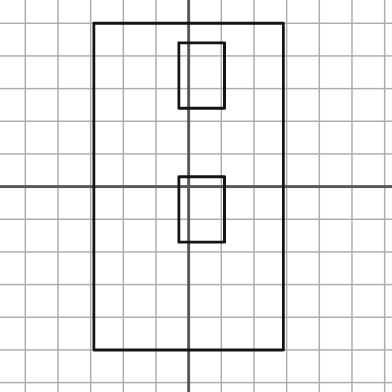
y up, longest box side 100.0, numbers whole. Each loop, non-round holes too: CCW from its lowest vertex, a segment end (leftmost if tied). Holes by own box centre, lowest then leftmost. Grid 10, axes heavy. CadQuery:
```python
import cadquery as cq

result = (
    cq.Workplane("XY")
    .moveTo(-29.0, -50.0)
    .lineTo(29.0, -50.0)
    .lineTo(29.0, 50.0)
    .lineTo(-29.0, 50.0)
    .close()
    .moveTo(-3.0, -17.0)
    .lineTo(11.0, -17.0)
    .lineTo(11.0, 3.0)
    .lineTo(-3.0, 3.0)
    .close()
    .moveTo(-3.0, 24.0)
    .lineTo(11.0, 24.0)
    .lineTo(11.0, 44.0)
    .lineTo(-3.0, 44.0)
    .close()
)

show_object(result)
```